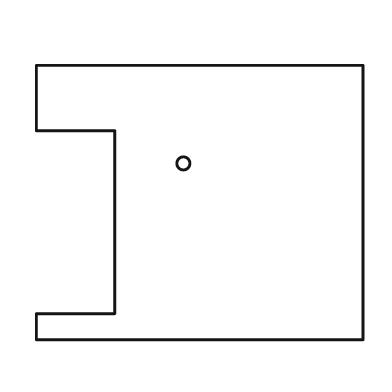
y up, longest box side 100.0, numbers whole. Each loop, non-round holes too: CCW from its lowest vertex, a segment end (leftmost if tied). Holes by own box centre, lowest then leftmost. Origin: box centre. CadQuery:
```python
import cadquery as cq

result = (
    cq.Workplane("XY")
    .moveTo(-50.0, -42.0)
    .lineTo(50.0, -42.0)
    .lineTo(50.0, 42.0)
    .lineTo(-50.0, 42.0)
    .lineTo(-50.0, 22.0)
    .lineTo(-26.0, 22.0)
    .lineTo(-26.0, -34.0)
    .lineTo(-50.0, -34.0)
    .close()
    .moveTo(-5.0, 12.0)
    .circle(2.0)
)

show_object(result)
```